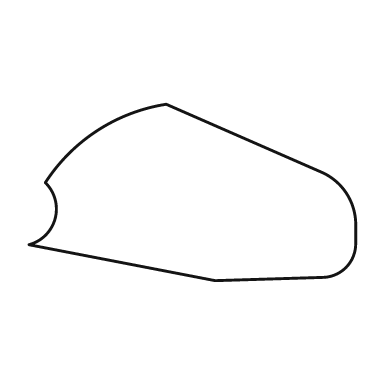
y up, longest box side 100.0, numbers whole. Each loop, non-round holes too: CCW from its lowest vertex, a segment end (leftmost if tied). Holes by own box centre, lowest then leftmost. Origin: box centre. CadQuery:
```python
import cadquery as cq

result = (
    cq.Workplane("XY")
    .moveTo(7.0, -27.0)
    .lineTo(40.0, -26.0)
    .threePointArc((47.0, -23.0), (50.0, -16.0))
    .lineTo(50.0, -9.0)
    .threePointArc((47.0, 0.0), (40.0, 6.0))
    .lineTo(-8.0, 27.0)
    .threePointArc((-29.0, 19.0), (-45.0, 3.0))
    .threePointArc((-42.0, -8.0), (-50.0, -16.0))
    .close()
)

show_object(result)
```